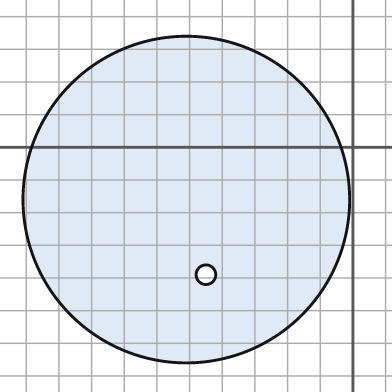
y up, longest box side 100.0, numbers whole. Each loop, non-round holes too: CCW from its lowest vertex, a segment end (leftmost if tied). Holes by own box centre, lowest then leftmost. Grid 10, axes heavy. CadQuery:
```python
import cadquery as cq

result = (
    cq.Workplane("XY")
    .moveTo(-51.0, -16.0)
    .circle(50.0)
    .moveTo(-45.0, -39.0)
    .circle(3.0)
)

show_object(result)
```